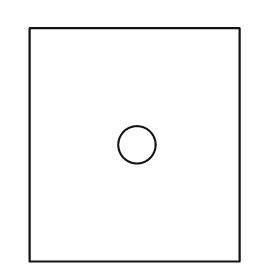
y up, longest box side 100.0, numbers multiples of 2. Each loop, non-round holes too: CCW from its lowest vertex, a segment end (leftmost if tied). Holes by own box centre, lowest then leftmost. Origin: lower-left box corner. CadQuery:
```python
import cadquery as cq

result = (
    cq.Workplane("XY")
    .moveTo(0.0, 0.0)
    .lineTo(90.0, 0.0)
    .lineTo(90.0, 100.0)
    .lineTo(0.0, 100.0)
    .close()
    .moveTo(46.0, 50.0)
    .circle(8.0)
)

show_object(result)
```